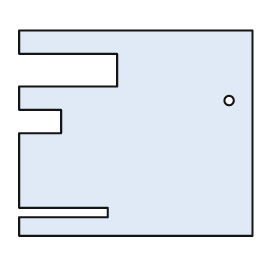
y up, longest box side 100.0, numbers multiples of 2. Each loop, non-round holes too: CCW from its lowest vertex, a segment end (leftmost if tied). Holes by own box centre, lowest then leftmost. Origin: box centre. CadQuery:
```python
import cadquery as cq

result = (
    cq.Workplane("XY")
    .moveTo(-50.0, -44.0)
    .lineTo(50.0, -44.0)
    .lineTo(50.0, 44.0)
    .lineTo(-50.0, 44.0)
    .lineTo(-50.0, 34.0)
    .lineTo(-8.0, 34.0)
    .lineTo(-8.0, 20.0)
    .lineTo(-50.0, 20.0)
    .lineTo(-50.0, 10.0)
    .lineTo(-32.0, 10.0)
    .lineTo(-32.0, 0.0)
    .lineTo(-50.0, 0.0)
    .lineTo(-50.0, -32.0)
    .lineTo(-12.0, -32.0)
    .lineTo(-12.0, -36.0)
    .lineTo(-50.0, -36.0)
    .close()
    .moveTo(40.0, 14.0)
    .circle(2.0)
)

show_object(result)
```